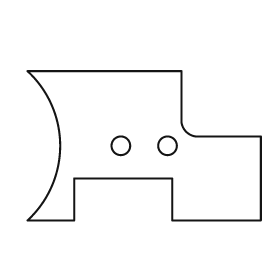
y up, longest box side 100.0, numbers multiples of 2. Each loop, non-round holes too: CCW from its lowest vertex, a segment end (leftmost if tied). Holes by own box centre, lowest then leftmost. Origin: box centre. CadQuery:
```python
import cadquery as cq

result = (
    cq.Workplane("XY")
    .moveTo(-50.0, -32.0)
    .lineTo(-30.0, -32.0)
    .lineTo(-30.0, -14.0)
    .lineTo(12.0, -14.0)
    .lineTo(12.0, -32.0)
    .lineTo(50.0, -32.0)
    .lineTo(50.0, 4.0)
    .lineTo(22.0, 4.0)
    .threePointArc((18.0, 6.0), (16.0, 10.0))
    .lineTo(16.0, 32.0)
    .lineTo(-50.0, 32.0)
    .threePointArc((-36.0, 0.0), (-50.0, -32.0))
    .close()
    .moveTo(-10.0, 0.0)
    .circle(4.0)
    .moveTo(10.0, 0.0)
    .circle(4.0)
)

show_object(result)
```